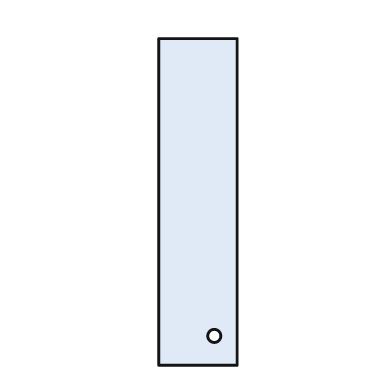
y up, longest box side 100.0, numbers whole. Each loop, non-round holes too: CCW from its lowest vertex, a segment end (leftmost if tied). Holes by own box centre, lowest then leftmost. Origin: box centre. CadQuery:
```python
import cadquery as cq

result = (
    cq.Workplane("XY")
    .moveTo(-12.0, -50.0)
    .lineTo(12.0, -50.0)
    .lineTo(12.0, 50.0)
    .lineTo(-12.0, 50.0)
    .close()
    .moveTo(5.0, -41.0)
    .circle(2.0)
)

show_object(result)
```